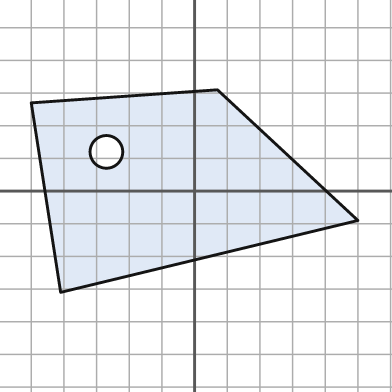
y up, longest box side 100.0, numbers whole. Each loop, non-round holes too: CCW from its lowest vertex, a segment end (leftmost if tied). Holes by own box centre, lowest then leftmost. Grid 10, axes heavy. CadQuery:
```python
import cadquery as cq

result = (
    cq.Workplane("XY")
    .moveTo(-41.0, -31.0)
    .lineTo(50.0, -9.0)
    .lineTo(7.0, 31.0)
    .lineTo(-50.0, 27.0)
    .close()
    .moveTo(-27.0, 12.0)
    .circle(5.0)
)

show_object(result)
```